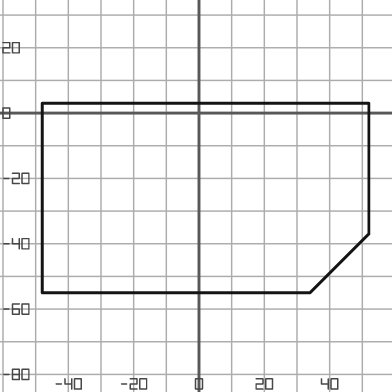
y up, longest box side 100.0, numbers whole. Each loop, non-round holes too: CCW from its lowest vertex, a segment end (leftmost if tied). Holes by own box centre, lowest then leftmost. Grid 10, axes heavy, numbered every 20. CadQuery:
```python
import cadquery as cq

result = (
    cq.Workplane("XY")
    .moveTo(-48.0, -55.0)
    .lineTo(34.0, -55.0)
    .lineTo(52.0, -37.0)
    .lineTo(52.0, 3.0)
    .lineTo(-48.0, 3.0)
    .close()
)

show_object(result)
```